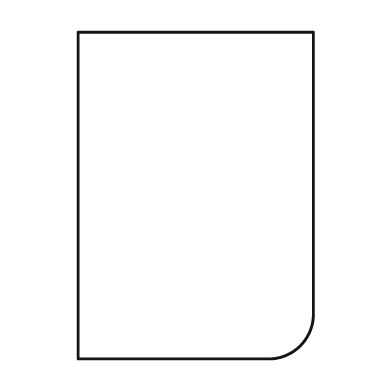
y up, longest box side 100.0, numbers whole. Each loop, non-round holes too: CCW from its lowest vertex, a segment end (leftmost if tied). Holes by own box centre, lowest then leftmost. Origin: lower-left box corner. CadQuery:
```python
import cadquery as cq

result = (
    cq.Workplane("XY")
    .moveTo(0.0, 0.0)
    .lineTo(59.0, 0.0)
    .threePointArc((68.0, 4.0), (72.0, 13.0))
    .lineTo(72.0, 100.0)
    .lineTo(0.0, 100.0)
    .close()
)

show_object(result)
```